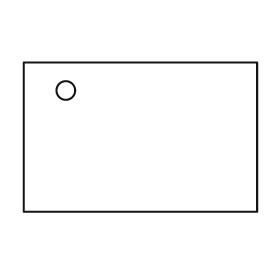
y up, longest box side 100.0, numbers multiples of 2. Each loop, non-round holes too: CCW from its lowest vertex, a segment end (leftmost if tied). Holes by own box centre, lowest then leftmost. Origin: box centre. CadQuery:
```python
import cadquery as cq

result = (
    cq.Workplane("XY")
    .moveTo(-50.0, -32.0)
    .lineTo(50.0, -32.0)
    .lineTo(50.0, 32.0)
    .lineTo(-50.0, 32.0)
    .close()
    .moveTo(-32.0, 20.0)
    .circle(4.0)
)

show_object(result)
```